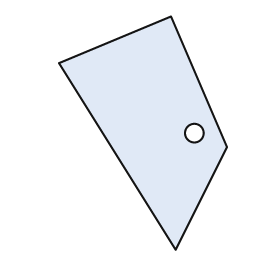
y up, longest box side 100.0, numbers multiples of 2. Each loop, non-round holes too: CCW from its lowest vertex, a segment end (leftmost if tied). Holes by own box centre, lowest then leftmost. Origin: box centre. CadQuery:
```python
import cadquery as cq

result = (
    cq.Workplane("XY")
    .moveTo(14.0, -50.0)
    .lineTo(36.0, -6.0)
    .lineTo(12.0, 50.0)
    .lineTo(-36.0, 30.0)
    .close()
    .moveTo(22.0, 0.0)
    .circle(4.0)
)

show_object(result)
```